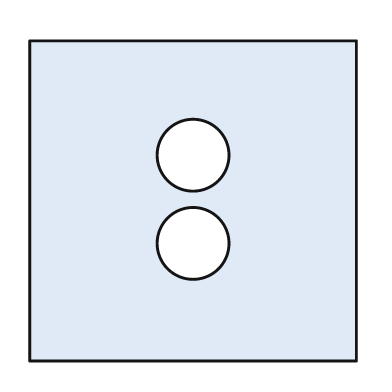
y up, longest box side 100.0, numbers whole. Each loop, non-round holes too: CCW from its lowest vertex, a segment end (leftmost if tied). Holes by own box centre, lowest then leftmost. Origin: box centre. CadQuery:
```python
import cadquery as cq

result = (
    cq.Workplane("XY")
    .moveTo(-50.0, -49.0)
    .lineTo(50.0, -49.0)
    .lineTo(50.0, 49.0)
    .lineTo(-50.0, 49.0)
    .close()
    .moveTo(0.0, -13.0)
    .circle(11.0)
    .moveTo(0.0, 14.0)
    .circle(11.0)
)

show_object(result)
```